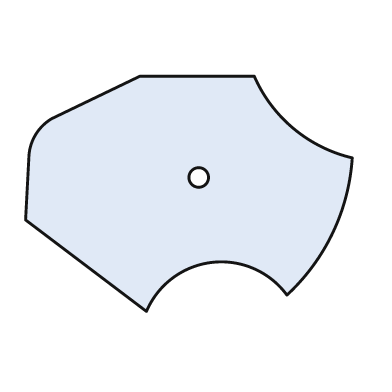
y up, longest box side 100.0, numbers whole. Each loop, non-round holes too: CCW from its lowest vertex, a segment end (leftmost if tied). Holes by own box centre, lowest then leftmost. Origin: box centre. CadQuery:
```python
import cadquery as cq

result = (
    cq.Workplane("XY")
    .moveTo(-13.0, -36.0)
    .threePointArc((7.0, -21.0), (30.0, -31.0))
    .threePointArc((44.0, -12.0), (50.0, 11.0))
    .threePointArc((32.0, 20.0), (20.0, 36.0))
    .lineTo(-15.0, 36.0)
    .lineTo(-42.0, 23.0)
    .threePointArc((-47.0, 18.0), (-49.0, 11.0))
    .lineTo(-50.0, -8.0)
    .close()
    .moveTo(3.0, 5.0)
    .circle(3.0)
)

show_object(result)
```